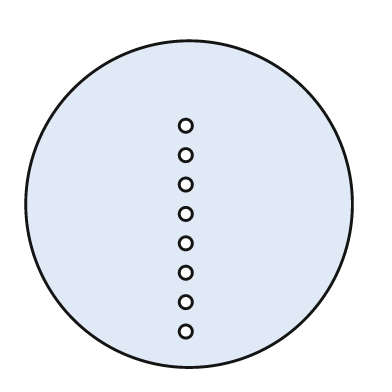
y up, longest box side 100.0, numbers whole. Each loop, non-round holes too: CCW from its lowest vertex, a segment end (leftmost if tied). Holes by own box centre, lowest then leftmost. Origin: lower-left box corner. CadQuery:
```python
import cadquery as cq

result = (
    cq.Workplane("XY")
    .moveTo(50.0, 50.0)
    .circle(50.0)
    .moveTo(49.0, 11.0)
    .circle(2.0)
    .moveTo(49.0, 20.0)
    .circle(2.0)
    .moveTo(49.0, 29.0)
    .circle(2.0)
    .moveTo(49.0, 38.0)
    .circle(2.0)
    .moveTo(49.0, 47.0)
    .circle(2.0)
    .moveTo(49.0, 56.0)
    .circle(2.0)
    .moveTo(49.0, 65.0)
    .circle(2.0)
    .moveTo(49.0, 74.0)
    .circle(2.0)
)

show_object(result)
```